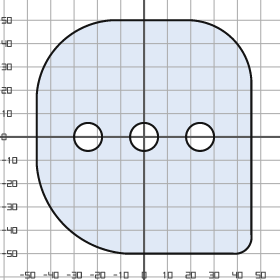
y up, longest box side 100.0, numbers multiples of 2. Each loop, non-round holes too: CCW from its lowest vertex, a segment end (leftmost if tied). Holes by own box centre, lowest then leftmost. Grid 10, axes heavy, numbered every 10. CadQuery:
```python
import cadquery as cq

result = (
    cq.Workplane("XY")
    .moveTo(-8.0, -50.0)
    .lineTo(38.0, -50.0)
    .threePointArc((44.0, -48.0), (46.0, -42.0))
    .lineTo(46.0, 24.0)
    .threePointArc((38.0, 42.0), (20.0, 50.0))
    .lineTo(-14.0, 50.0)
    .threePointArc((-36.0, 40.0), (-46.0, 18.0))
    .lineTo(-46.0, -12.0)
    .threePointArc((-34.0, -38.0), (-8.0, -50.0))
    .close()
    .moveTo(-24.0, 0.0)
    .circle(6.0)
    .moveTo(0.0, 0.0)
    .circle(6.0)
    .moveTo(24.0, 0.0)
    .circle(6.0)
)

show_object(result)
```